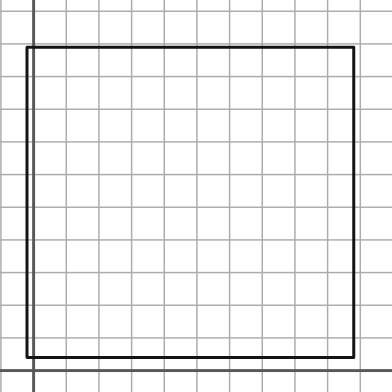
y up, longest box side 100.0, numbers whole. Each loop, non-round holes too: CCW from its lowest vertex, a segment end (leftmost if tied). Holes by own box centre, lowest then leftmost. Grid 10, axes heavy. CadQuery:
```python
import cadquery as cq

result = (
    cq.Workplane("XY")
    .moveTo(-2.0, 4.0)
    .lineTo(98.0, 4.0)
    .lineTo(98.0, 99.0)
    .lineTo(-2.0, 99.0)
    .close()
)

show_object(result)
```